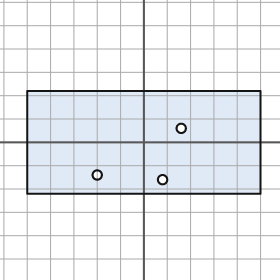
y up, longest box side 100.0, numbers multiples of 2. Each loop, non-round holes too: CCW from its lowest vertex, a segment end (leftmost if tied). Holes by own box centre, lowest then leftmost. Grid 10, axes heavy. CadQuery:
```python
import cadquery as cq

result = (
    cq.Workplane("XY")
    .moveTo(-50.0, -22.0)
    .lineTo(50.0, -22.0)
    .lineTo(50.0, 22.0)
    .lineTo(-50.0, 22.0)
    .close()
    .moveTo(8.0, -16.0)
    .circle(2.0)
    .moveTo(-20.0, -14.0)
    .circle(2.0)
    .moveTo(16.0, 6.0)
    .circle(2.0)
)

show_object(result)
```